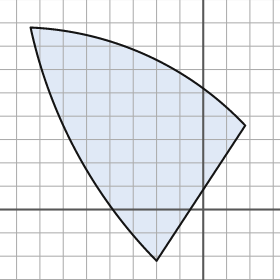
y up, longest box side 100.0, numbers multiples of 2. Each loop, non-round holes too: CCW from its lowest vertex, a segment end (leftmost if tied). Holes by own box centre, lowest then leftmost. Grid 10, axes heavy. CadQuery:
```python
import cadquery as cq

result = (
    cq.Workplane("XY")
    .moveTo(-20.0, -22.0)
    .lineTo(18.0, 36.0)
    .threePointArc((-24.0, 66.0), (-74.0, 78.0))
    .threePointArc((-54.0, 24.0), (-20.0, -22.0))
    .close()
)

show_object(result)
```